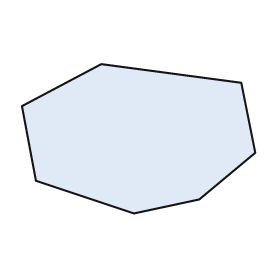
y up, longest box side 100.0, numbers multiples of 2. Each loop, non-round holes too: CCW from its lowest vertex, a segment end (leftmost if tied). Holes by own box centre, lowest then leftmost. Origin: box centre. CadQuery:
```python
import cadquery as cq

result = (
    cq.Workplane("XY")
    .moveTo(-2.0, -32.0)
    .lineTo(26.0, -26.0)
    .lineTo(50.0, -6.0)
    .lineTo(44.0, 24.0)
    .lineTo(-16.0, 32.0)
    .lineTo(-50.0, 14.0)
    .lineTo(-44.0, -18.0)
    .close()
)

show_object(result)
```